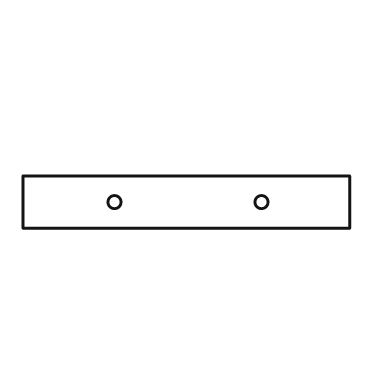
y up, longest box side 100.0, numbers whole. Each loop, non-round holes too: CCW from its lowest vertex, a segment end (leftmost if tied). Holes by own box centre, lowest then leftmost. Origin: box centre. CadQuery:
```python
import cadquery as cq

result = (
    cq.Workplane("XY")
    .moveTo(-50.0, -8.0)
    .lineTo(50.0, -8.0)
    .lineTo(50.0, 8.0)
    .lineTo(-50.0, 8.0)
    .close()
    .moveTo(-22.0, 0.0)
    .circle(2.0)
    .moveTo(23.0, 0.0)
    .circle(2.0)
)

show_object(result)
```